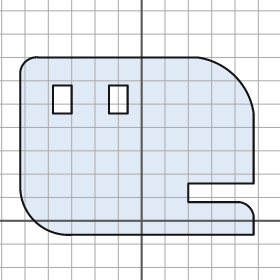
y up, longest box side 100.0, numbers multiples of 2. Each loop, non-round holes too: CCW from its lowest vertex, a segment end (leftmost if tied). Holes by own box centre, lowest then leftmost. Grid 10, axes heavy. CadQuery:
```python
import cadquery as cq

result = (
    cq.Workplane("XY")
    .moveTo(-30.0, -6.0)
    .lineTo(48.0, -6.0)
    .lineTo(48.0, 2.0)
    .threePointArc((46.0, 6.0), (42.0, 8.0))
    .lineTo(20.0, 8.0)
    .lineTo(20.0, 16.0)
    .lineTo(48.0, 16.0)
    .lineTo(48.0, 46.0)
    .threePointArc((40.0, 62.0), (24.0, 70.0))
    .lineTo(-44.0, 70.0)
    .threePointArc((-50.0, 68.0), (-52.0, 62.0))
    .lineTo(-52.0, 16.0)
    .threePointArc((-46.0, 0.0), (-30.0, -6.0))
    .close()
    .moveTo(-38.0, 46.0)
    .lineTo(-30.0, 46.0)
    .lineTo(-30.0, 58.0)
    .lineTo(-38.0, 58.0)
    .close()
    .moveTo(-14.0, 46.0)
    .lineTo(-6.0, 46.0)
    .lineTo(-6.0, 58.0)
    .lineTo(-14.0, 58.0)
    .close()
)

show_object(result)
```